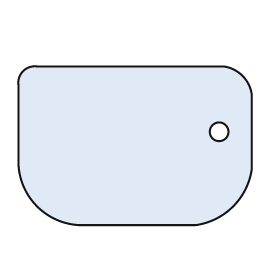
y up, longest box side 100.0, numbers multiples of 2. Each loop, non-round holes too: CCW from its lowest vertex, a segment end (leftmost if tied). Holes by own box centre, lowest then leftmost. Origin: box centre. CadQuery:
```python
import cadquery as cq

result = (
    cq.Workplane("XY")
    .moveTo(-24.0, -34.0)
    .lineTo(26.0, -34.0)
    .threePointArc((42.0, -26.0), (50.0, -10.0))
    .lineTo(50.0, 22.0)
    .threePointArc((46.0, 30.0), (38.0, 34.0))
    .lineTo(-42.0, 34.0)
    .threePointArc((-48.0, 32.0), (-50.0, 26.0))
    .lineTo(-50.0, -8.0)
    .threePointArc((-42.0, -26.0), (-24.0, -34.0))
    .close()
    .moveTo(36.0, 6.0)
    .circle(4.0)
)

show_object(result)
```